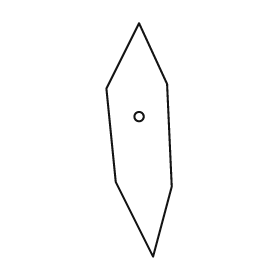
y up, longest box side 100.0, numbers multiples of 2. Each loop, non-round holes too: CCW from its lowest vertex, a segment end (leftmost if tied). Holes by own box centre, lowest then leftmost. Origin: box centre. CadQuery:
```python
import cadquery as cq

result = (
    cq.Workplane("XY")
    .moveTo(6.0, -50.0)
    .lineTo(14.0, -20.0)
    .lineTo(12.0, 24.0)
    .lineTo(0.0, 50.0)
    .lineTo(-14.0, 22.0)
    .lineTo(-10.0, -18.0)
    .close()
    .moveTo(0.0, 10.0)
    .circle(2.0)
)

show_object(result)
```